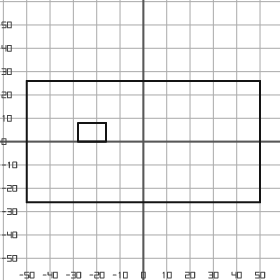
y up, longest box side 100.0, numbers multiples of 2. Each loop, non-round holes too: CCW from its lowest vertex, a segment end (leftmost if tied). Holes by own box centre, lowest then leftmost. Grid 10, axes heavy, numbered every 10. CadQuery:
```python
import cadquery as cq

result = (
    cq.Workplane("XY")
    .moveTo(-50.0, -26.0)
    .lineTo(50.0, -26.0)
    .lineTo(50.0, 26.0)
    .lineTo(-50.0, 26.0)
    .close()
    .moveTo(-28.0, 0.0)
    .lineTo(-16.0, 0.0)
    .lineTo(-16.0, 8.0)
    .lineTo(-28.0, 8.0)
    .close()
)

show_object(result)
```